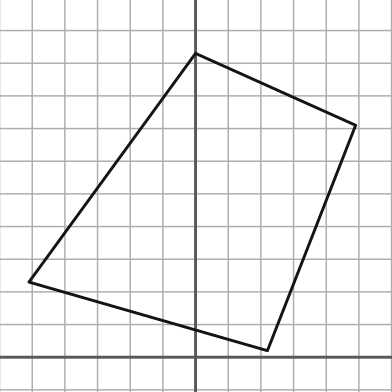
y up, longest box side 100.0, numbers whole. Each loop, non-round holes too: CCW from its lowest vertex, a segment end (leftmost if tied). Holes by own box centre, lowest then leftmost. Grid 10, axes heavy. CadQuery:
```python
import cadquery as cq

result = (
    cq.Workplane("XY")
    .moveTo(22.0, 2.0)
    .lineTo(49.0, 71.0)
    .lineTo(0.0, 93.0)
    .lineTo(-51.0, 23.0)
    .close()
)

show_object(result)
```